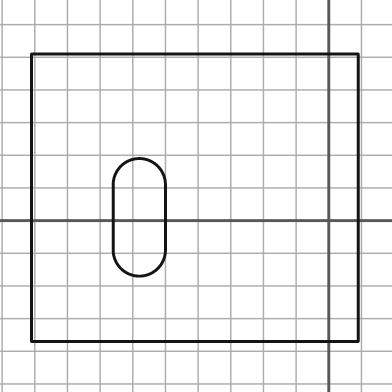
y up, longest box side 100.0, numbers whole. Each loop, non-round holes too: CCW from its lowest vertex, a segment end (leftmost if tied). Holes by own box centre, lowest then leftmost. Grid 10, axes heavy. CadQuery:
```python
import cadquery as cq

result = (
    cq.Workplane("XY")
    .moveTo(-91.0, -37.0)
    .lineTo(9.0, -37.0)
    .lineTo(9.0, 51.0)
    .lineTo(-91.0, 51.0)
    .close()
    .moveTo(-66.0, -9.0)
    .threePointArc((-58.0, -17.0), (-50.0, -9.0))
    .lineTo(-50.0, 11.0)
    .threePointArc((-58.0, 19.0), (-66.0, 11.0))
    .close()
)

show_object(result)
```